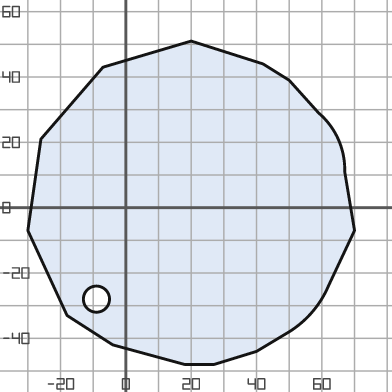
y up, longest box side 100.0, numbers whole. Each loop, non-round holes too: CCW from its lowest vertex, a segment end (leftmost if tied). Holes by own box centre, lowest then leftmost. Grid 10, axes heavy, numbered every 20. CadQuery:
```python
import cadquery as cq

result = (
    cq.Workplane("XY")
    .moveTo(18.0, -48.0)
    .lineTo(27.0, -48.0)
    .lineTo(40.0, -44.0)
    .lineTo(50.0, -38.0)
    .threePointArc((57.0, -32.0), (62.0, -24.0))
    .lineTo(70.0, -7.0)
    .lineTo(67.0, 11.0)
    .threePointArc((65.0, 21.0), (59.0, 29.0))
    .lineTo(50.0, 39.0)
    .lineTo(42.0, 44.0)
    .lineTo(20.0, 51.0)
    .lineTo(-7.0, 43.0)
    .lineTo(-26.0, 21.0)
    .lineTo(-30.0, -7.0)
    .lineTo(-18.0, -33.0)
    .lineTo(-4.0, -42.0)
    .close()
    .moveTo(-9.0, -28.0)
    .circle(4.0)
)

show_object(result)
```